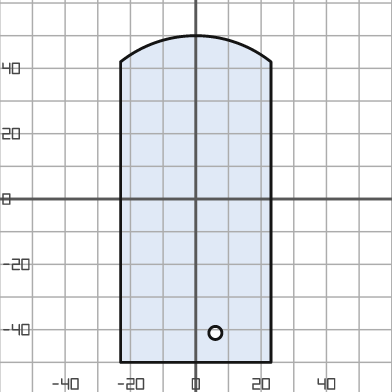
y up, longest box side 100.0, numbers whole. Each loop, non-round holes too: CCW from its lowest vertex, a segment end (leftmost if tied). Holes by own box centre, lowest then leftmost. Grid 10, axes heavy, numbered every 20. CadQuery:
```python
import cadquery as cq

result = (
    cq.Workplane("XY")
    .moveTo(-23.0, -50.0)
    .lineTo(23.0, -50.0)
    .lineTo(23.0, 42.0)
    .threePointArc((0.0, 50.0), (-23.0, 42.0))
    .close()
    .moveTo(6.0, -41.0)
    .circle(2.0)
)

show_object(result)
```